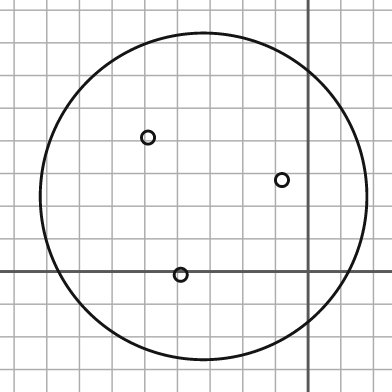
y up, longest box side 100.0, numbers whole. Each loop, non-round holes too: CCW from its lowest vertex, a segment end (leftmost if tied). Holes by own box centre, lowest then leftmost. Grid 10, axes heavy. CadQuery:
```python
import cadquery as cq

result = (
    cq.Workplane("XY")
    .moveTo(-32.0, 23.0)
    .circle(50.0)
    .moveTo(-39.0, -1.0)
    .circle(2.0)
    .moveTo(-8.0, 28.0)
    .circle(2.0)
    .moveTo(-49.0, 41.0)
    .circle(2.0)
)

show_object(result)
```